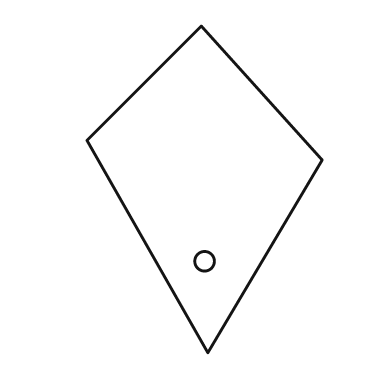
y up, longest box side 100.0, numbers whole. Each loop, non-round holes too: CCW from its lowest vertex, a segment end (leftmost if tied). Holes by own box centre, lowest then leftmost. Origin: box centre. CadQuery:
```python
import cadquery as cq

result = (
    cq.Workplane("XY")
    .moveTo(1.0, -50.0)
    .lineTo(36.0, 9.0)
    .lineTo(-1.0, 50.0)
    .lineTo(-36.0, 15.0)
    .close()
    .moveTo(0.0, -22.0)
    .circle(3.0)
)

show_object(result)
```